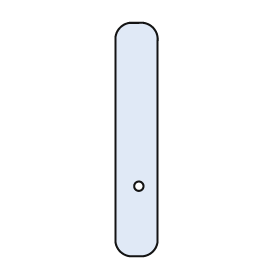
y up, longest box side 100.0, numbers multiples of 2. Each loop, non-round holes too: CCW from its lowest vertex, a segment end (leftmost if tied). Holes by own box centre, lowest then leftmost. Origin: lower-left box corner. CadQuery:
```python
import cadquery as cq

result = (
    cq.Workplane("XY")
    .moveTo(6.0, 0.0)
    .lineTo(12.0, 0.0)
    .threePointArc((16.0, 2.0), (18.0, 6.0))
    .lineTo(18.0, 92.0)
    .threePointArc((16.0, 98.0), (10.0, 100.0))
    .lineTo(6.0, 100.0)
    .threePointArc((2.0, 98.0), (0.0, 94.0))
    .lineTo(0.0, 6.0)
    .threePointArc((2.0, 2.0), (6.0, 0.0))
    .close()
    .moveTo(10.0, 30.0)
    .circle(2.0)
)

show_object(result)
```